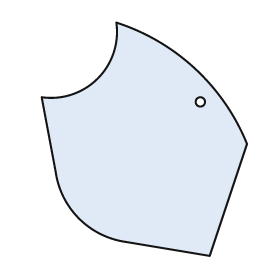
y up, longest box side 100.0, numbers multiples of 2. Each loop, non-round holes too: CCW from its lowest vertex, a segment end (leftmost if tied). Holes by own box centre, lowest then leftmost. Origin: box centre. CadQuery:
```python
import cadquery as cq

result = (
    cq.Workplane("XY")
    .moveTo(28.0, -50.0)
    .lineTo(44.0, -2.0)
    .threePointArc((22.0, 30.0), (-12.0, 50.0))
    .threePointArc((-20.0, 26.0), (-44.0, 18.0))
    .lineTo(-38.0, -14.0)
    .threePointArc((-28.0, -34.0), (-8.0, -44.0))
    .close()
    .moveTo(24.0, 16.0)
    .circle(2.0)
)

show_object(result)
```